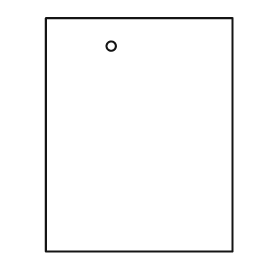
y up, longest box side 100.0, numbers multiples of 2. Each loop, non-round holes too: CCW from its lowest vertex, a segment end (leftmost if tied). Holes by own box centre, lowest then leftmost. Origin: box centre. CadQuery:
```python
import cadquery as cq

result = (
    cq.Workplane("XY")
    .moveTo(-40.0, -50.0)
    .lineTo(40.0, -50.0)
    .lineTo(40.0, 50.0)
    .lineTo(-40.0, 50.0)
    .close()
    .moveTo(-12.0, 38.0)
    .circle(2.0)
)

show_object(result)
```